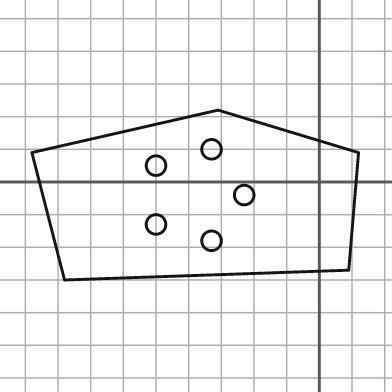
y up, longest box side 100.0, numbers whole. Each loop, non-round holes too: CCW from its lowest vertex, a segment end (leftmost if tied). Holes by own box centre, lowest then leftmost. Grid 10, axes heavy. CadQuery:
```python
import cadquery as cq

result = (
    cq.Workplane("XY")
    .moveTo(-78.0, -30.0)
    .lineTo(9.0, -27.0)
    .lineTo(12.0, 9.0)
    .lineTo(-31.0, 22.0)
    .lineTo(-88.0, 9.0)
    .close()
    .moveTo(-33.0, -18.0)
    .circle(3.0)
    .moveTo(-50.0, -13.0)
    .circle(3.0)
    .moveTo(-23.0, -4.0)
    .circle(3.0)
    .moveTo(-50.0, 5.0)
    .circle(3.0)
    .moveTo(-33.0, 10.0)
    .circle(3.0)
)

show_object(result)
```